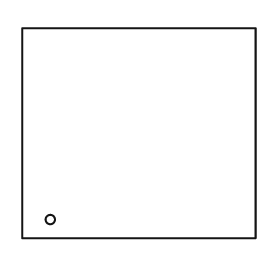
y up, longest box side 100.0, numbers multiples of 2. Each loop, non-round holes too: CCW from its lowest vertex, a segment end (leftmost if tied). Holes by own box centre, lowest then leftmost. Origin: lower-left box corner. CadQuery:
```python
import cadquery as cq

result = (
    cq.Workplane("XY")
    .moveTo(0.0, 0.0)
    .lineTo(100.0, 0.0)
    .lineTo(100.0, 90.0)
    .lineTo(0.0, 90.0)
    .close()
    .moveTo(12.0, 8.0)
    .circle(2.0)
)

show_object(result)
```